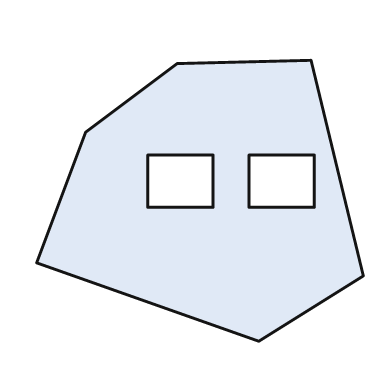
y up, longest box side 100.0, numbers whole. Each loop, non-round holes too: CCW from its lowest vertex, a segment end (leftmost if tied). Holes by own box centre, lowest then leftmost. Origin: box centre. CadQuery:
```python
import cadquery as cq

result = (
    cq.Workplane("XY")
    .moveTo(18.0, -43.0)
    .lineTo(50.0, -23.0)
    .lineTo(34.0, 43.0)
    .lineTo(-7.0, 42.0)
    .lineTo(-35.0, 21.0)
    .lineTo(-50.0, -19.0)
    .close()
    .moveTo(-16.0, -2.0)
    .lineTo(4.0, -2.0)
    .lineTo(4.0, 14.0)
    .lineTo(-16.0, 14.0)
    .close()
    .moveTo(15.0, -2.0)
    .lineTo(35.0, -2.0)
    .lineTo(35.0, 14.0)
    .lineTo(15.0, 14.0)
    .close()
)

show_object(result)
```